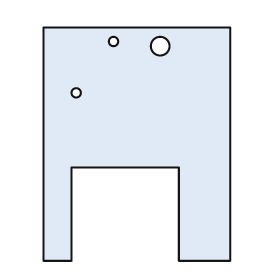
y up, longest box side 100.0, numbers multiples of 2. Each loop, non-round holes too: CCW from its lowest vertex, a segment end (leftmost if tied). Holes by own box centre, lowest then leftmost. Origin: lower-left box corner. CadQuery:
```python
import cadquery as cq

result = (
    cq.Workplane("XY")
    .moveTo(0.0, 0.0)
    .lineTo(12.0, 0.0)
    .lineTo(12.0, 40.0)
    .lineTo(58.0, 40.0)
    .lineTo(58.0, 0.0)
    .lineTo(80.0, 0.0)
    .lineTo(80.0, 100.0)
    .lineTo(0.0, 100.0)
    .close()
    .moveTo(14.0, 72.0)
    .circle(2.0)
    .moveTo(50.0, 92.0)
    .circle(4.0)
    .moveTo(30.0, 94.0)
    .circle(2.0)
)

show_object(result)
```